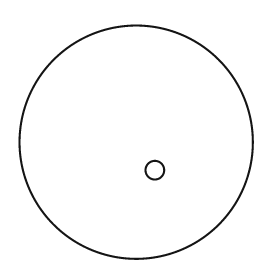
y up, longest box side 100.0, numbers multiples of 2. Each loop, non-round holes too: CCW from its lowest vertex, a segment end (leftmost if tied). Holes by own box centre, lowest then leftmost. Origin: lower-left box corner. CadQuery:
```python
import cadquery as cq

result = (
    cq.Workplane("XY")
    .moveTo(50.0, 50.0)
    .circle(50.0)
    .moveTo(58.0, 38.0)
    .circle(4.0)
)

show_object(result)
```